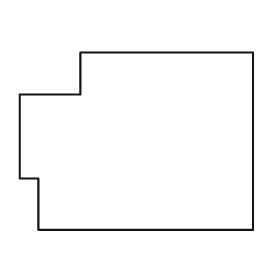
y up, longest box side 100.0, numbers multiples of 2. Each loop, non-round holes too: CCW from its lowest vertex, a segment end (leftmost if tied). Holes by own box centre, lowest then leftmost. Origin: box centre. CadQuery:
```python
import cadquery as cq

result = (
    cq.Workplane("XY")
    .moveTo(-42.0, -38.0)
    .lineTo(50.0, -38.0)
    .lineTo(50.0, 38.0)
    .lineTo(-24.0, 38.0)
    .lineTo(-24.0, 20.0)
    .lineTo(-50.0, 20.0)
    .lineTo(-50.0, -16.0)
    .lineTo(-42.0, -16.0)
    .close()
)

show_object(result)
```